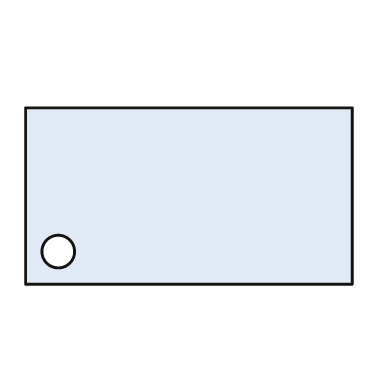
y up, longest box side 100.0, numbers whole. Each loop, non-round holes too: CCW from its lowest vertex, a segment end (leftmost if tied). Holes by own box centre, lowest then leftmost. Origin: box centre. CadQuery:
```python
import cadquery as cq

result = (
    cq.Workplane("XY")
    .moveTo(-50.0, -27.0)
    .lineTo(50.0, -27.0)
    .lineTo(50.0, 27.0)
    .lineTo(-50.0, 27.0)
    .close()
    .moveTo(-40.0, -17.0)
    .circle(5.0)
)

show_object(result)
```